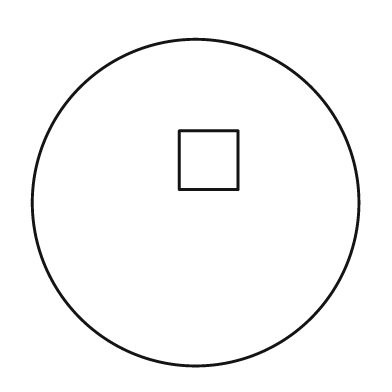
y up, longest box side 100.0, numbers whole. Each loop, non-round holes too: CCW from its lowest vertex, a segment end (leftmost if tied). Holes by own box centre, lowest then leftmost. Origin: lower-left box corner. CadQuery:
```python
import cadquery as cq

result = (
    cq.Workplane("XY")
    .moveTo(50.0, 50.0)
    .circle(50.0)
    .moveTo(45.0, 54.0)
    .lineTo(63.0, 54.0)
    .lineTo(63.0, 72.0)
    .lineTo(45.0, 72.0)
    .close()
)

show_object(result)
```